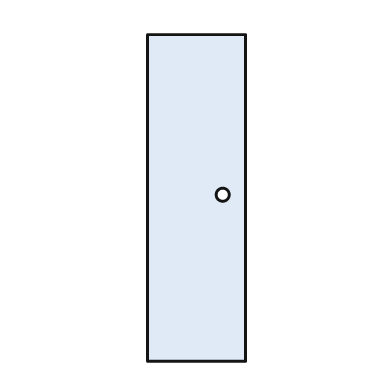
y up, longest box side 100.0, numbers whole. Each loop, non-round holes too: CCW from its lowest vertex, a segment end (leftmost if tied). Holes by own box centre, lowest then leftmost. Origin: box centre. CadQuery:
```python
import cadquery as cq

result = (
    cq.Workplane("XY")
    .moveTo(-15.0, -50.0)
    .lineTo(15.0, -50.0)
    .lineTo(15.0, 50.0)
    .lineTo(-15.0, 50.0)
    .close()
    .moveTo(8.0, 1.0)
    .circle(2.0)
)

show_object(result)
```